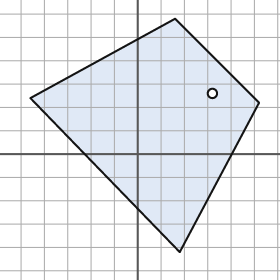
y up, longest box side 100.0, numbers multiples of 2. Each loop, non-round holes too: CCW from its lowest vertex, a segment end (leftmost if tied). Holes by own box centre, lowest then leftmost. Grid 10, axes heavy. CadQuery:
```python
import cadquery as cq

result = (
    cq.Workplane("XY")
    .moveTo(18.0, -42.0)
    .lineTo(52.0, 22.0)
    .lineTo(16.0, 58.0)
    .lineTo(-46.0, 24.0)
    .close()
    .moveTo(32.0, 26.0)
    .circle(2.0)
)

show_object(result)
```